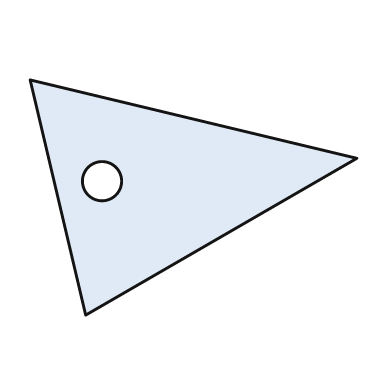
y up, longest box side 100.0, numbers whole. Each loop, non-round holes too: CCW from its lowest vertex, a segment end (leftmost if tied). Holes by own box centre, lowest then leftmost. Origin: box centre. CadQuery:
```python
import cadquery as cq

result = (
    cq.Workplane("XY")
    .moveTo(-33.0, -36.0)
    .lineTo(50.0, 12.0)
    .lineTo(-50.0, 36.0)
    .close()
    .moveTo(-28.0, 5.0)
    .circle(6.0)
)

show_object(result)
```